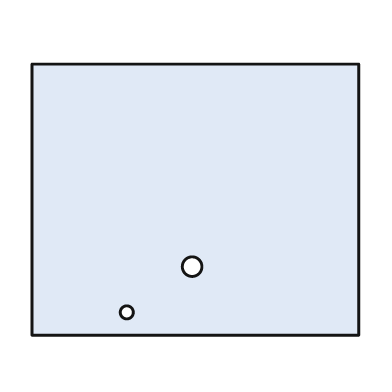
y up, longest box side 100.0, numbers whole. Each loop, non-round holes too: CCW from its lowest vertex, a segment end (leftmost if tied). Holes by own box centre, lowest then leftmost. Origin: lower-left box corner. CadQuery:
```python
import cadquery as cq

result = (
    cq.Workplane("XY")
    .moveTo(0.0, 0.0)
    .lineTo(100.0, 0.0)
    .lineTo(100.0, 83.0)
    .lineTo(0.0, 83.0)
    .close()
    .moveTo(29.0, 7.0)
    .circle(2.0)
    .moveTo(49.0, 21.0)
    .circle(3.0)
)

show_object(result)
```